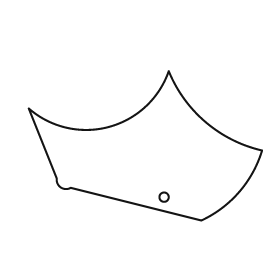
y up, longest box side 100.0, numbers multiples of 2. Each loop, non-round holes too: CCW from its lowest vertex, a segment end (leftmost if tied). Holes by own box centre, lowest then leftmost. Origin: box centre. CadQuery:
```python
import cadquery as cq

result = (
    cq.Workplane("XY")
    .moveTo(24.0, -32.0)
    .threePointArc((40.0, -20.0), (50.0, -2.0))
    .threePointArc((26.0, 10.0), (10.0, 32.0))
    .threePointArc((-16.0, 8.0), (-50.0, 16.0))
    .lineTo(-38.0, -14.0)
    .threePointArc((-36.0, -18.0), (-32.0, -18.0))
    .close()
    .moveTo(8.0, -22.0)
    .circle(2.0)
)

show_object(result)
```